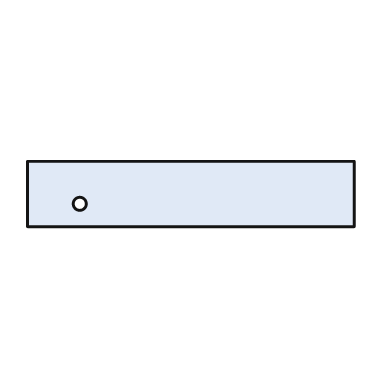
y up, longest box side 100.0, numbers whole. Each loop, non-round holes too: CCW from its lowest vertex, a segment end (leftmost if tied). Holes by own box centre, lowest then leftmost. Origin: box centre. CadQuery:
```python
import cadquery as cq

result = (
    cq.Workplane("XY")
    .moveTo(-50.0, -10.0)
    .lineTo(50.0, -10.0)
    .lineTo(50.0, 10.0)
    .lineTo(-50.0, 10.0)
    .close()
    .moveTo(-34.0, -3.0)
    .circle(2.0)
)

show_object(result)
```